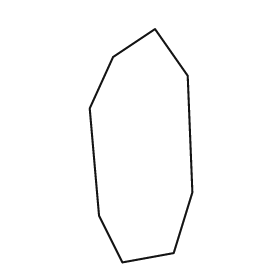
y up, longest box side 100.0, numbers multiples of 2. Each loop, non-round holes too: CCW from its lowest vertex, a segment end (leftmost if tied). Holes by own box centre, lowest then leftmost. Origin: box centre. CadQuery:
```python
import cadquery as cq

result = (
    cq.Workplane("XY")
    .moveTo(-8.0, -50.0)
    .lineTo(14.0, -46.0)
    .lineTo(22.0, -20.0)
    .lineTo(20.0, 30.0)
    .lineTo(6.0, 50.0)
    .lineTo(-12.0, 38.0)
    .lineTo(-22.0, 16.0)
    .lineTo(-18.0, -30.0)
    .close()
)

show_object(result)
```